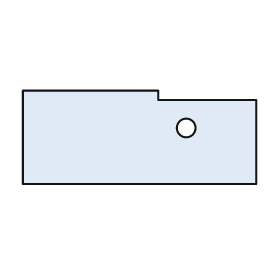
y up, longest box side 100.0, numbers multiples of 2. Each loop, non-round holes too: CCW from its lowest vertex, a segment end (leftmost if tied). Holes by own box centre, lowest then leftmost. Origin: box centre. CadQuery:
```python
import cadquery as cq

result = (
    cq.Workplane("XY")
    .moveTo(-50.0, -20.0)
    .lineTo(50.0, -20.0)
    .lineTo(50.0, 16.0)
    .lineTo(8.0, 16.0)
    .lineTo(8.0, 20.0)
    .lineTo(-50.0, 20.0)
    .close()
    .moveTo(20.0, 4.0)
    .circle(4.0)
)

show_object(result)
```